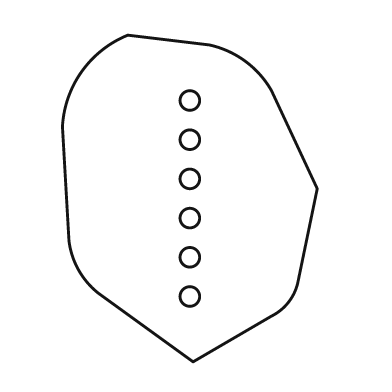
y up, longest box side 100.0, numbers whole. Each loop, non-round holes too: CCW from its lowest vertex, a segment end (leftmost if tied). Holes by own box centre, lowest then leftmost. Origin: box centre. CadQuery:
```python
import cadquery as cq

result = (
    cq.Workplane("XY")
    .moveTo(1.0, -50.0)
    .lineTo(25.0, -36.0)
    .threePointArc((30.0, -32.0), (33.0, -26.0))
    .lineTo(39.0, 3.0)
    .lineTo(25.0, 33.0)
    .threePointArc((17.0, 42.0), (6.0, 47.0))
    .lineTo(-19.0, 50.0)
    .threePointArc((-33.0, 39.0), (-39.0, 22.0))
    .lineTo(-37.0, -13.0)
    .threePointArc((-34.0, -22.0), (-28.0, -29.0))
    .close()
    .moveTo(0.0, -30.0)
    .circle(3.0)
    .moveTo(0.0, -18.0)
    .circle(3.0)
    .moveTo(0.0, -6.0)
    .circle(3.0)
    .moveTo(0.0, 6.0)
    .circle(3.0)
    .moveTo(0.0, 18.0)
    .circle(3.0)
    .moveTo(0.0, 30.0)
    .circle(3.0)
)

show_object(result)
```